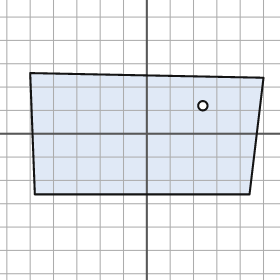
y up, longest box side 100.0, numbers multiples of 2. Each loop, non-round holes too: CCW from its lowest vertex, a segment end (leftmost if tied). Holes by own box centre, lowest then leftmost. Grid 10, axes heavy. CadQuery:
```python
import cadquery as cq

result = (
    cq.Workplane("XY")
    .moveTo(-48.0, -26.0)
    .lineTo(44.0, -26.0)
    .lineTo(50.0, 24.0)
    .lineTo(-50.0, 26.0)
    .close()
    .moveTo(24.0, 12.0)
    .circle(2.0)
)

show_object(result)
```